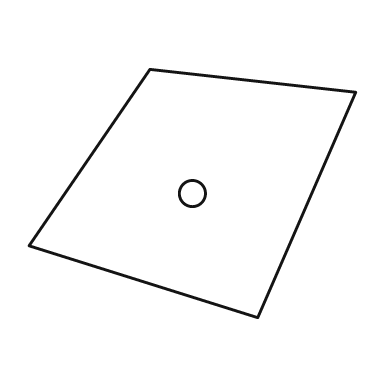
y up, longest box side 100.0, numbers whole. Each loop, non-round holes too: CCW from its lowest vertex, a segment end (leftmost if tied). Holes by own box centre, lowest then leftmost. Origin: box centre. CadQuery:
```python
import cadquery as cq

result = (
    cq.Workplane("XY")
    .moveTo(20.0, -38.0)
    .lineTo(50.0, 31.0)
    .lineTo(-13.0, 38.0)
    .lineTo(-50.0, -16.0)
    .close()
    .moveTo(0.0, 0.0)
    .circle(4.0)
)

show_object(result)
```